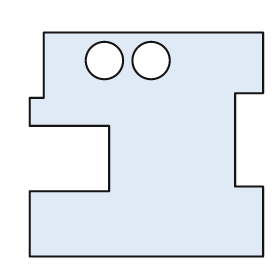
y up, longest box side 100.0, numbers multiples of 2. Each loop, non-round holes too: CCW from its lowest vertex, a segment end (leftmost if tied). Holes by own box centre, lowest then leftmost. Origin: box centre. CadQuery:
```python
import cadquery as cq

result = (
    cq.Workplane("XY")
    .moveTo(-50.0, -48.0)
    .lineTo(50.0, -48.0)
    .lineTo(50.0, -18.0)
    .lineTo(38.0, -18.0)
    .lineTo(38.0, 22.0)
    .lineTo(50.0, 22.0)
    .lineTo(50.0, 48.0)
    .lineTo(-44.0, 48.0)
    .lineTo(-44.0, 20.0)
    .lineTo(-50.0, 20.0)
    .lineTo(-50.0, 8.0)
    .lineTo(-16.0, 8.0)
    .lineTo(-16.0, -20.0)
    .lineTo(-50.0, -20.0)
    .close()
    .moveTo(-18.0, 36.0)
    .circle(8.0)
    .moveTo(2.0, 36.0)
    .circle(8.0)
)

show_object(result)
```